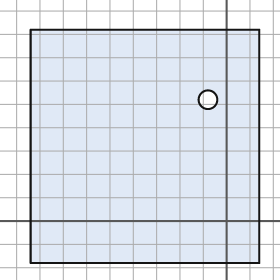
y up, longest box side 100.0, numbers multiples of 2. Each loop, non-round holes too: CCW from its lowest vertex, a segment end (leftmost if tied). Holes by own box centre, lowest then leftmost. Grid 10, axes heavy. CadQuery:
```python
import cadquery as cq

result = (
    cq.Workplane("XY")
    .moveTo(-84.0, -18.0)
    .lineTo(14.0, -18.0)
    .lineTo(14.0, 82.0)
    .lineTo(-84.0, 82.0)
    .close()
    .moveTo(-8.0, 52.0)
    .circle(4.0)
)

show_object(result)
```